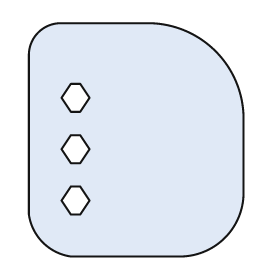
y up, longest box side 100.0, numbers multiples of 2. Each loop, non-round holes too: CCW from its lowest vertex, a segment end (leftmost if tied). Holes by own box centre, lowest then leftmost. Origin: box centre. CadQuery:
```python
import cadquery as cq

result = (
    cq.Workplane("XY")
    .moveTo(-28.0, -50.0)
    .lineTo(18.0, -50.0)
    .threePointArc((38.0, -42.0), (46.0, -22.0))
    .lineTo(46.0, 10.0)
    .threePointArc((34.0, 38.0), (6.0, 50.0))
    .lineTo(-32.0, 50.0)
    .threePointArc((-42.0, 46.0), (-46.0, 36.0))
    .lineTo(-46.0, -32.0)
    .threePointArc((-40.0, -44.0), (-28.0, -50.0))
    .close()
    .moveTo(-28.0, -32.0)
    .lineTo(-24.0, -32.0)
    .lineTo(-20.0, -26.0)
    .lineTo(-24.0, -20.0)
    .lineTo(-28.0, -20.0)
    .lineTo(-32.0, -26.0)
    .close()
    .moveTo(-28.0, -10.0)
    .lineTo(-24.0, -10.0)
    .lineTo(-20.0, -4.0)
    .lineTo(-24.0, 2.0)
    .lineTo(-28.0, 2.0)
    .lineTo(-32.0, -4.0)
    .close()
    .moveTo(-28.0, 12.0)
    .lineTo(-24.0, 12.0)
    .lineTo(-20.0, 18.0)
    .lineTo(-24.0, 24.0)
    .lineTo(-28.0, 24.0)
    .lineTo(-32.0, 18.0)
    .close()
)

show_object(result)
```